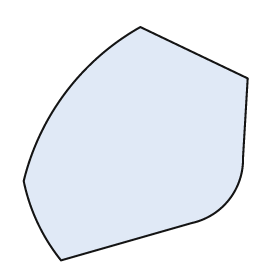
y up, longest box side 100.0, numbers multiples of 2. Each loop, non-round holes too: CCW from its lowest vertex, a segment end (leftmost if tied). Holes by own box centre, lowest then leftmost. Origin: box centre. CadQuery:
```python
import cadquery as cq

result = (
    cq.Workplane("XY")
    .moveTo(-32.0, -50.0)
    .lineTo(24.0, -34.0)
    .threePointArc((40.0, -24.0), (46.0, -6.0))
    .lineTo(48.0, 28.0)
    .lineTo(2.0, 50.0)
    .threePointArc((-30.0, 22.0), (-48.0, -16.0))
    .threePointArc((-42.0, -34.0), (-32.0, -50.0))
    .close()
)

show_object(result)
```